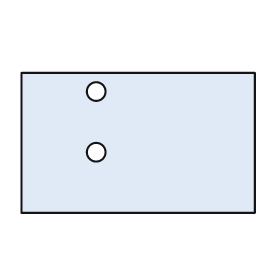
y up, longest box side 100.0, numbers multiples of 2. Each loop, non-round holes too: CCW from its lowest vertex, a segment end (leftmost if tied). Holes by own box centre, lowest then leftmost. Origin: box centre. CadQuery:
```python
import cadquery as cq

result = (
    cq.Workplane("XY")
    .moveTo(-50.0, -30.0)
    .lineTo(50.0, -30.0)
    .lineTo(50.0, 30.0)
    .lineTo(-50.0, 30.0)
    .close()
    .moveTo(-18.0, -4.0)
    .circle(4.0)
    .moveTo(-18.0, 22.0)
    .circle(4.0)
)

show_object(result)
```